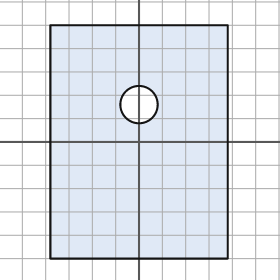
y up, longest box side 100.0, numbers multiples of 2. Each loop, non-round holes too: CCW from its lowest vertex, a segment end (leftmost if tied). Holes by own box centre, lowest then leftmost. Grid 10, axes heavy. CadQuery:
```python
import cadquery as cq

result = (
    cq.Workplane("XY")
    .moveTo(-38.0, -50.0)
    .lineTo(38.0, -50.0)
    .lineTo(38.0, 50.0)
    .lineTo(-38.0, 50.0)
    .close()
    .moveTo(0.0, 16.0)
    .circle(8.0)
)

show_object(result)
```